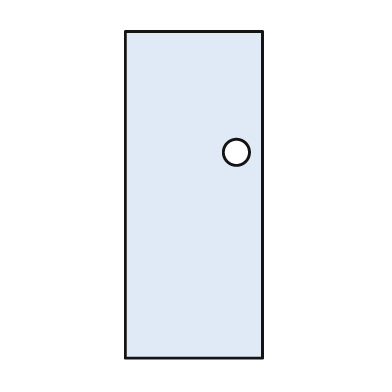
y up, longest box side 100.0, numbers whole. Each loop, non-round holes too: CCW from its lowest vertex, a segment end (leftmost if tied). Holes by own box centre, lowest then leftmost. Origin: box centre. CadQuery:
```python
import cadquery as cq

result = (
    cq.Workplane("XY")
    .moveTo(-21.0, -50.0)
    .lineTo(21.0, -50.0)
    .lineTo(21.0, 50.0)
    .lineTo(-21.0, 50.0)
    .close()
    .moveTo(13.0, 13.0)
    .circle(4.0)
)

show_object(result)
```